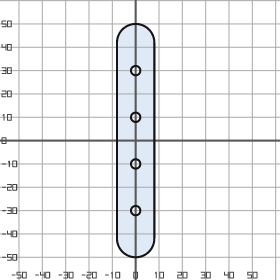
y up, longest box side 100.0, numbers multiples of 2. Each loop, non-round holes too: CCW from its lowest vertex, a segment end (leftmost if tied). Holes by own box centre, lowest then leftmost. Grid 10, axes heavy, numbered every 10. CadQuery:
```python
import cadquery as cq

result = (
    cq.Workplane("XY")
    .moveTo(-8.0, -42.0)
    .threePointArc((0.0, -50.0), (8.0, -42.0))
    .lineTo(8.0, 42.0)
    .threePointArc((0.0, 50.0), (-8.0, 42.0))
    .close()
    .moveTo(0.0, -30.0)
    .circle(2.0)
    .moveTo(0.0, -10.0)
    .circle(2.0)
    .moveTo(0.0, 10.0)
    .circle(2.0)
    .moveTo(0.0, 30.0)
    .circle(2.0)
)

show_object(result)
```